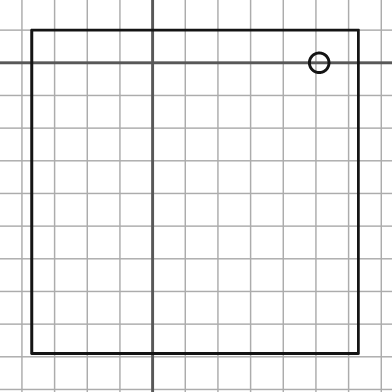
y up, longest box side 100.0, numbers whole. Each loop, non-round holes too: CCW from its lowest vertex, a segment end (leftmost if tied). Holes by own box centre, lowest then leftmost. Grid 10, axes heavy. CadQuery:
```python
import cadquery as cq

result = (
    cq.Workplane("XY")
    .moveTo(-37.0, -89.0)
    .lineTo(63.0, -89.0)
    .lineTo(63.0, 10.0)
    .lineTo(-37.0, 10.0)
    .close()
    .moveTo(51.0, 0.0)
    .circle(3.0)
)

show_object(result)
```